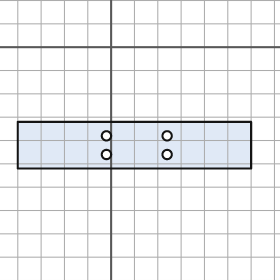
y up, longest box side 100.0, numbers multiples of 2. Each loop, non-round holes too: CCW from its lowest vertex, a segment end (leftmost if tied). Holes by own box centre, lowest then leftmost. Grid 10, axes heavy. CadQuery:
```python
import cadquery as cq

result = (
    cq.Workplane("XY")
    .moveTo(-40.0, -52.0)
    .lineTo(60.0, -52.0)
    .lineTo(60.0, -32.0)
    .lineTo(-40.0, -32.0)
    .close()
    .moveTo(-2.0, -46.0)
    .circle(2.0)
    .moveTo(24.0, -46.0)
    .circle(2.0)
    .moveTo(-2.0, -38.0)
    .circle(2.0)
    .moveTo(24.0, -38.0)
    .circle(2.0)
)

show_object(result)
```